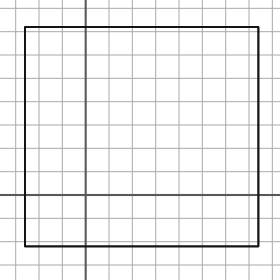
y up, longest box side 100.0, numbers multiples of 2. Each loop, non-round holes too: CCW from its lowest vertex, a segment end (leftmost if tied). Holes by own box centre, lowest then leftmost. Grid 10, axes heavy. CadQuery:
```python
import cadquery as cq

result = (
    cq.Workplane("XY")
    .moveTo(-26.0, -22.0)
    .lineTo(74.0, -22.0)
    .lineTo(74.0, 72.0)
    .lineTo(-26.0, 72.0)
    .close()
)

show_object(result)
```